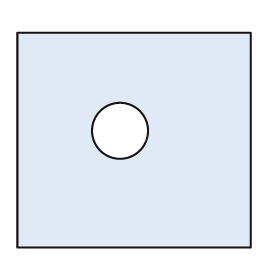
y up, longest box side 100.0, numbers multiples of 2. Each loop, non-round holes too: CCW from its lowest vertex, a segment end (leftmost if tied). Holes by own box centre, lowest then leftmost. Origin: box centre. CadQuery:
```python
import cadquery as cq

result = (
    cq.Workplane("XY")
    .moveTo(-50.0, -46.0)
    .lineTo(50.0, -46.0)
    .lineTo(50.0, 46.0)
    .lineTo(-50.0, 46.0)
    .close()
    .moveTo(-6.0, 4.0)
    .circle(12.0)
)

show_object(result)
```